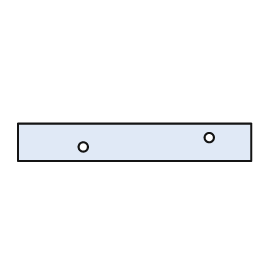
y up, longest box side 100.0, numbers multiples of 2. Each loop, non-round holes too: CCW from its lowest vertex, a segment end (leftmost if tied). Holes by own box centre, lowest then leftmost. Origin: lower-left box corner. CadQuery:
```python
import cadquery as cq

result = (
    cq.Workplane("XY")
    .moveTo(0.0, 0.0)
    .lineTo(100.0, 0.0)
    .lineTo(100.0, 16.0)
    .lineTo(0.0, 16.0)
    .close()
    .moveTo(28.0, 6.0)
    .circle(2.0)
    .moveTo(82.0, 10.0)
    .circle(2.0)
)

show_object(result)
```